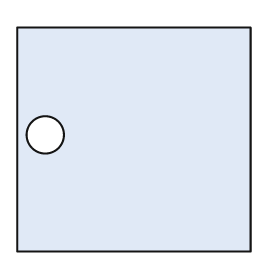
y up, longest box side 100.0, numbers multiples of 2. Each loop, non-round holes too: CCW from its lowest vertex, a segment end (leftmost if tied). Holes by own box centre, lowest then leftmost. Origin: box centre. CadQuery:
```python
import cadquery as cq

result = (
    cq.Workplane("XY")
    .moveTo(-50.0, -48.0)
    .lineTo(50.0, -48.0)
    .lineTo(50.0, 48.0)
    .lineTo(-50.0, 48.0)
    .close()
    .moveTo(-38.0, 2.0)
    .circle(8.0)
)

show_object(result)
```